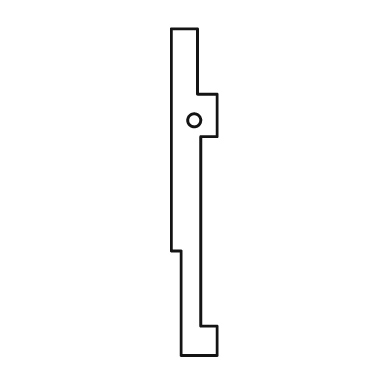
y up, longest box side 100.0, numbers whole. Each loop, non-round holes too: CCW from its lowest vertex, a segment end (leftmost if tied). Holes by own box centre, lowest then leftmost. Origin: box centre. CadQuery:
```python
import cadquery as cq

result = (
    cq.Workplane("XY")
    .moveTo(-4.0, -50.0)
    .lineTo(7.0, -50.0)
    .lineTo(7.0, -41.0)
    .lineTo(2.0, -41.0)
    .lineTo(2.0, 17.0)
    .lineTo(7.0, 17.0)
    .lineTo(7.0, 30.0)
    .lineTo(1.0, 30.0)
    .lineTo(1.0, 50.0)
    .lineTo(-7.0, 50.0)
    .lineTo(-7.0, -18.0)
    .lineTo(-4.0, -18.0)
    .close()
    .moveTo(0.0, 22.0)
    .circle(2.0)
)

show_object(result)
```